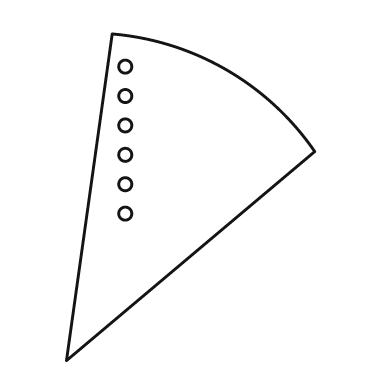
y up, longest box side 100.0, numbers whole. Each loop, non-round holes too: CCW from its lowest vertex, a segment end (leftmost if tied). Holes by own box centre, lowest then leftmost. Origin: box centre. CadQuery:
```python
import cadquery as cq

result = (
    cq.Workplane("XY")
    .moveTo(-38.0, -50.0)
    .lineTo(38.0, 14.0)
    .threePointArc((11.0, 39.0), (-24.0, 50.0))
    .close()
    .moveTo(-20.0, -5.0)
    .circle(2.0)
    .moveTo(-20.0, 4.0)
    .circle(2.0)
    .moveTo(-20.0, 13.0)
    .circle(2.0)
    .moveTo(-20.0, 22.0)
    .circle(2.0)
    .moveTo(-20.0, 31.0)
    .circle(2.0)
    .moveTo(-20.0, 40.0)
    .circle(2.0)
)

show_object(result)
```